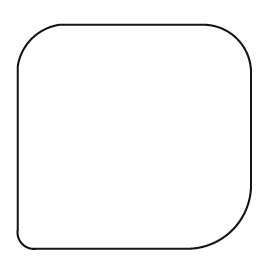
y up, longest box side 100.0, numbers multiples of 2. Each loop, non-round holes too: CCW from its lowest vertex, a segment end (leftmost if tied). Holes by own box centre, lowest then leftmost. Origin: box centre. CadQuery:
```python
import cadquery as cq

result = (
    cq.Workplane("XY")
    .moveTo(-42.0, -48.0)
    .lineTo(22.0, -48.0)
    .threePointArc((42.0, -40.0), (50.0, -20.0))
    .lineTo(50.0, 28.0)
    .threePointArc((44.0, 42.0), (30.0, 48.0))
    .lineTo(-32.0, 48.0)
    .threePointArc((-44.0, 42.0), (-50.0, 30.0))
    .lineTo(-50.0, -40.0)
    .threePointArc((-48.0, -46.0), (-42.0, -48.0))
    .close()
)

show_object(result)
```